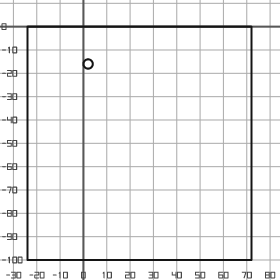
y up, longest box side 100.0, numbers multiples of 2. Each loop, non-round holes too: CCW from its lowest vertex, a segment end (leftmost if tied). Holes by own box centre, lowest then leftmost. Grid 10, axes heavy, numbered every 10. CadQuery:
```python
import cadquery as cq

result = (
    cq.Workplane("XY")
    .moveTo(-24.0, -100.0)
    .lineTo(72.0, -100.0)
    .lineTo(72.0, 0.0)
    .lineTo(-24.0, 0.0)
    .close()
    .moveTo(2.0, -16.0)
    .circle(2.0)
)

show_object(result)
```